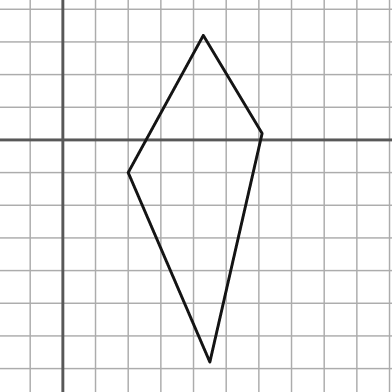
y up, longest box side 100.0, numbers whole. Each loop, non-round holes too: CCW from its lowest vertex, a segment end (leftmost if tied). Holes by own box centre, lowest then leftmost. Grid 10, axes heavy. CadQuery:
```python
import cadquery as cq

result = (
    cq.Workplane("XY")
    .moveTo(45.0, -68.0)
    .lineTo(61.0, 2.0)
    .lineTo(43.0, 32.0)
    .lineTo(20.0, -10.0)
    .close()
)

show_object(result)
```